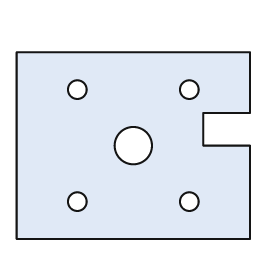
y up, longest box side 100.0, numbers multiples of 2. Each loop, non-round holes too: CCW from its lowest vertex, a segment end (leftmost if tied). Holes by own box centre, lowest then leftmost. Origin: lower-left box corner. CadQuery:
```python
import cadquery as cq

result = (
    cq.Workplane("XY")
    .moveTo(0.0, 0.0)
    .lineTo(100.0, 0.0)
    .lineTo(100.0, 40.0)
    .lineTo(80.0, 40.0)
    .lineTo(80.0, 54.0)
    .lineTo(100.0, 54.0)
    .lineTo(100.0, 80.0)
    .lineTo(0.0, 80.0)
    .close()
    .moveTo(26.0, 16.0)
    .circle(4.0)
    .moveTo(74.0, 16.0)
    .circle(4.0)
    .moveTo(50.0, 40.0)
    .circle(8.0)
    .moveTo(26.0, 64.0)
    .circle(4.0)
    .moveTo(74.0, 64.0)
    .circle(4.0)
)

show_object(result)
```